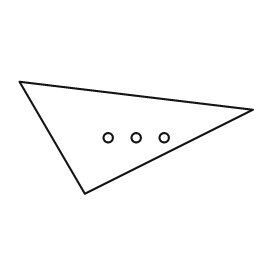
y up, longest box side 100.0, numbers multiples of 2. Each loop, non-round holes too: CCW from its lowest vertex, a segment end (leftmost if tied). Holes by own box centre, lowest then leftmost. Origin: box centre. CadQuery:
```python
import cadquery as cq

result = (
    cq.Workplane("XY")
    .moveTo(-22.0, -24.0)
    .lineTo(50.0, 12.0)
    .lineTo(-50.0, 24.0)
    .close()
    .moveTo(-12.0, 0.0)
    .circle(2.0)
    .moveTo(0.0, 0.0)
    .circle(2.0)
    .moveTo(12.0, 0.0)
    .circle(2.0)
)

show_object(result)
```